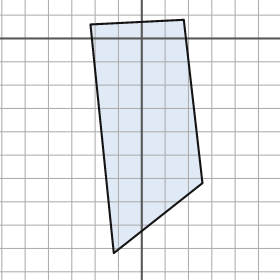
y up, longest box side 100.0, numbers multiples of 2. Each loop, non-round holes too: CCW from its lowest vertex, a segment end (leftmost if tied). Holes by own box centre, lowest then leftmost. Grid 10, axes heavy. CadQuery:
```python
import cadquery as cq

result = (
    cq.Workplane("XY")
    .moveTo(-12.0, -92.0)
    .lineTo(26.0, -62.0)
    .lineTo(18.0, 8.0)
    .lineTo(-22.0, 6.0)
    .close()
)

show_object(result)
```